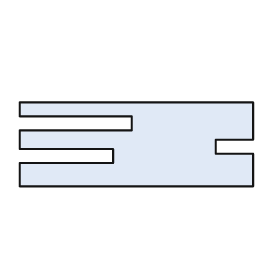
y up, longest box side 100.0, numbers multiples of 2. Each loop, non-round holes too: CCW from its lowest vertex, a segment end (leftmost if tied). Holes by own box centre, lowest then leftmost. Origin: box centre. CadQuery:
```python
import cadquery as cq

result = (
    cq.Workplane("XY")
    .moveTo(-50.0, -18.0)
    .lineTo(50.0, -18.0)
    .lineTo(50.0, -4.0)
    .lineTo(34.0, -4.0)
    .lineTo(34.0, 2.0)
    .lineTo(50.0, 2.0)
    .lineTo(50.0, 18.0)
    .lineTo(-50.0, 18.0)
    .lineTo(-50.0, 12.0)
    .lineTo(-2.0, 12.0)
    .lineTo(-2.0, 6.0)
    .lineTo(-50.0, 6.0)
    .lineTo(-50.0, -2.0)
    .lineTo(-10.0, -2.0)
    .lineTo(-10.0, -8.0)
    .lineTo(-50.0, -8.0)
    .close()
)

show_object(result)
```